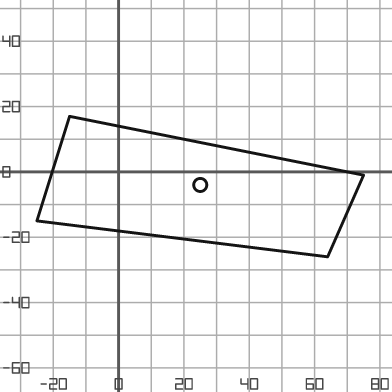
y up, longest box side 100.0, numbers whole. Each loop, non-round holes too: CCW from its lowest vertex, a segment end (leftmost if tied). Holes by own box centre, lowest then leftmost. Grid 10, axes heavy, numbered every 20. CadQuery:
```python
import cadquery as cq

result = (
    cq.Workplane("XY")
    .moveTo(64.0, -26.0)
    .lineTo(75.0, -1.0)
    .lineTo(-15.0, 17.0)
    .lineTo(-25.0, -15.0)
    .close()
    .moveTo(25.0, -4.0)
    .circle(2.0)
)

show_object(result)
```